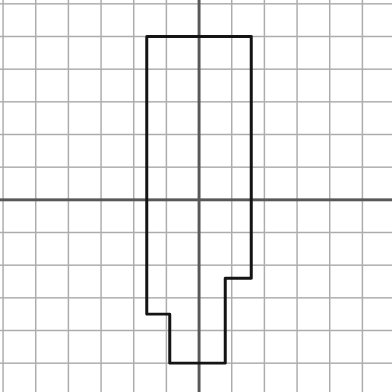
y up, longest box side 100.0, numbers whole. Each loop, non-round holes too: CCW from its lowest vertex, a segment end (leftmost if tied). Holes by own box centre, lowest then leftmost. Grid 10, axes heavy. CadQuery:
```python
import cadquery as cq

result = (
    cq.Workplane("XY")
    .moveTo(-9.0, -50.0)
    .lineTo(8.0, -50.0)
    .lineTo(8.0, -24.0)
    .lineTo(16.0, -24.0)
    .lineTo(16.0, 50.0)
    .lineTo(-16.0, 50.0)
    .lineTo(-16.0, -35.0)
    .lineTo(-9.0, -35.0)
    .close()
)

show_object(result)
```